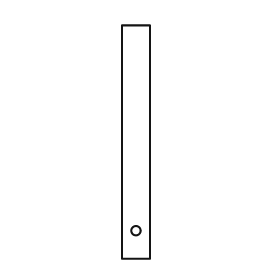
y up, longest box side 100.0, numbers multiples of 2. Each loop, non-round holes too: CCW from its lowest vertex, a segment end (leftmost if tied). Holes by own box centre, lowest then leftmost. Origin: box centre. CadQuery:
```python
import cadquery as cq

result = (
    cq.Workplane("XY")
    .moveTo(-6.0, -50.0)
    .lineTo(6.0, -50.0)
    .lineTo(6.0, 50.0)
    .lineTo(-6.0, 50.0)
    .close()
    .moveTo(0.0, -38.0)
    .circle(2.0)
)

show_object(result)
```